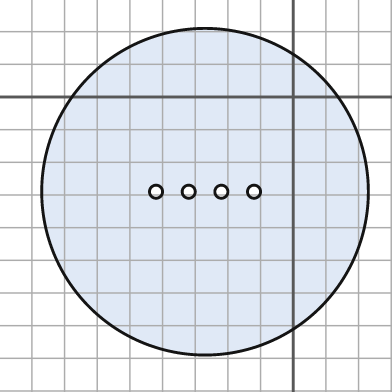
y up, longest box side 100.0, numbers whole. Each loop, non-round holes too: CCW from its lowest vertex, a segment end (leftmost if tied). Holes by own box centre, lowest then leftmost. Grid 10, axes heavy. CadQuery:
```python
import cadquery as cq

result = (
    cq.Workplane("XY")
    .moveTo(-27.0, -29.0)
    .circle(50.0)
    .moveTo(-42.0, -29.0)
    .circle(2.0)
    .moveTo(-32.0, -29.0)
    .circle(2.0)
    .moveTo(-22.0, -29.0)
    .circle(2.0)
    .moveTo(-12.0, -29.0)
    .circle(2.0)
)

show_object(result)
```